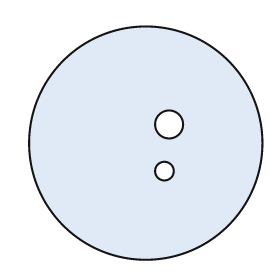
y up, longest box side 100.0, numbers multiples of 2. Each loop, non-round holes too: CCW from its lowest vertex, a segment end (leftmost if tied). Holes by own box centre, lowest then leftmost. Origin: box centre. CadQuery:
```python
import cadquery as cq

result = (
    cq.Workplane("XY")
    .moveTo(0.0, 0.0)
    .circle(50.0)
    .moveTo(8.0, -12.0)
    .circle(4.0)
    .moveTo(10.0, 8.0)
    .circle(6.0)
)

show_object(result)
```